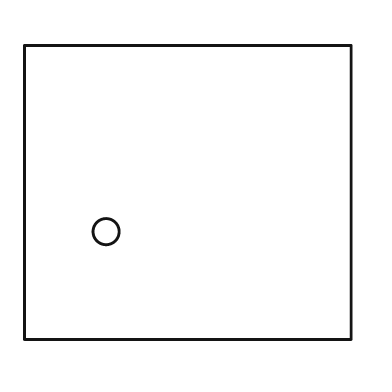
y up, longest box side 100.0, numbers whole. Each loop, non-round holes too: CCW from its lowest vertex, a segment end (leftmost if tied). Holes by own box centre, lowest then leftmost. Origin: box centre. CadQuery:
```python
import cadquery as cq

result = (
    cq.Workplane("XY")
    .moveTo(-50.0, -45.0)
    .lineTo(50.0, -45.0)
    .lineTo(50.0, 45.0)
    .lineTo(-50.0, 45.0)
    .close()
    .moveTo(-25.0, -12.0)
    .circle(4.0)
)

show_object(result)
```